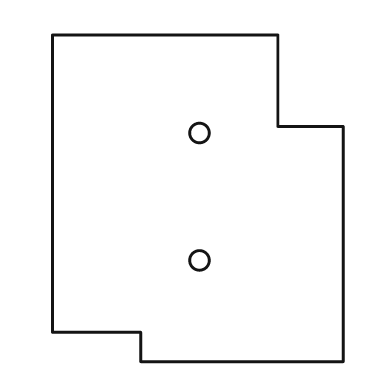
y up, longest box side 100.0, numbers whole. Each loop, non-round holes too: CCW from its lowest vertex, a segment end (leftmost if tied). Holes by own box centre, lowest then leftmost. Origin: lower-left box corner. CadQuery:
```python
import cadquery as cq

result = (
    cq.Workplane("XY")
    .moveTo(27.0, 0.0)
    .lineTo(89.0, 0.0)
    .lineTo(89.0, 72.0)
    .lineTo(69.0, 72.0)
    .lineTo(69.0, 100.0)
    .lineTo(0.0, 100.0)
    .lineTo(0.0, 9.0)
    .lineTo(27.0, 9.0)
    .close()
    .moveTo(45.0, 31.0)
    .circle(3.0)
    .moveTo(45.0, 70.0)
    .circle(3.0)
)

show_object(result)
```